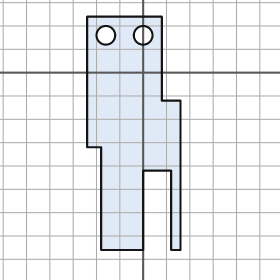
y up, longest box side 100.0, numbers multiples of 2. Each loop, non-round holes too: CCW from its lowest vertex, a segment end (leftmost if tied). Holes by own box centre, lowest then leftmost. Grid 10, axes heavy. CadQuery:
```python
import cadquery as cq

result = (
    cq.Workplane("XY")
    .moveTo(-18.0, -76.0)
    .lineTo(0.0, -76.0)
    .lineTo(0.0, -42.0)
    .lineTo(12.0, -42.0)
    .lineTo(12.0, -76.0)
    .lineTo(16.0, -76.0)
    .lineTo(16.0, -12.0)
    .lineTo(8.0, -12.0)
    .lineTo(8.0, 24.0)
    .lineTo(-24.0, 24.0)
    .lineTo(-24.0, -32.0)
    .lineTo(-18.0, -32.0)
    .close()
    .moveTo(-16.0, 16.0)
    .circle(4.0)
    .moveTo(0.0, 16.0)
    .circle(4.0)
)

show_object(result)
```